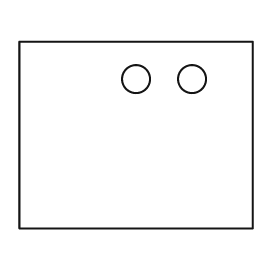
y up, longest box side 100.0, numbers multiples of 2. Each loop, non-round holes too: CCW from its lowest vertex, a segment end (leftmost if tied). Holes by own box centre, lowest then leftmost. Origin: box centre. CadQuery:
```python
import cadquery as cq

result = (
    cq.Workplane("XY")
    .moveTo(-50.0, -40.0)
    .lineTo(50.0, -40.0)
    .lineTo(50.0, 40.0)
    .lineTo(-50.0, 40.0)
    .close()
    .moveTo(0.0, 24.0)
    .circle(6.0)
    .moveTo(24.0, 24.0)
    .circle(6.0)
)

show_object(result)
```